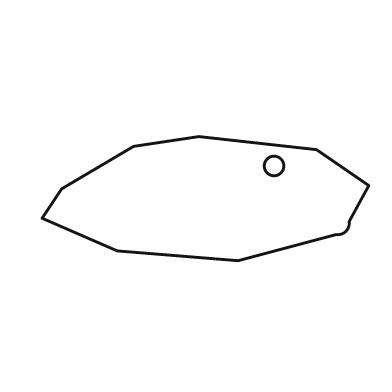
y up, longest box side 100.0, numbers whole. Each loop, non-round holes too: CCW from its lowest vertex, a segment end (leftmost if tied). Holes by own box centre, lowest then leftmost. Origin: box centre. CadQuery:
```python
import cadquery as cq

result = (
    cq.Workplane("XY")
    .moveTo(10.0, -19.0)
    .lineTo(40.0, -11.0)
    .threePointArc((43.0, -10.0), (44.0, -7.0))
    .lineTo(50.0, 4.0)
    .lineTo(34.0, 15.0)
    .lineTo(-2.0, 19.0)
    .lineTo(-22.0, 16.0)
    .lineTo(-44.0, 3.0)
    .lineTo(-50.0, -6.0)
    .lineTo(-27.0, -16.0)
    .close()
    .moveTo(21.0, 10.0)
    .circle(3.0)
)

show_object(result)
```